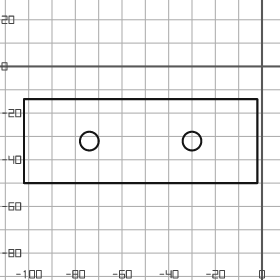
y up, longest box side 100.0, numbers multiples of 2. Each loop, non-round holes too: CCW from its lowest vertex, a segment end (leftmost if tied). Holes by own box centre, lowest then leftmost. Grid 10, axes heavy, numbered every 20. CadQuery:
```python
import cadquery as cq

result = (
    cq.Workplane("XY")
    .moveTo(-102.0, -50.0)
    .lineTo(-2.0, -50.0)
    .lineTo(-2.0, -14.0)
    .lineTo(-102.0, -14.0)
    .close()
    .moveTo(-74.0, -32.0)
    .circle(4.0)
    .moveTo(-30.0, -32.0)
    .circle(4.0)
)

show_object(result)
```